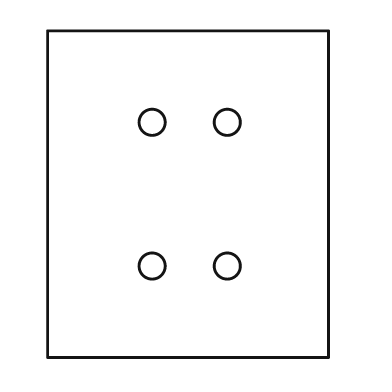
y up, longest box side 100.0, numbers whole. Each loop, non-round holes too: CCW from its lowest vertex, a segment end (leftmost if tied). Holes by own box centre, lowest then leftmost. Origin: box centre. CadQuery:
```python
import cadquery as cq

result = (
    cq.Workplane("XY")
    .moveTo(-43.0, -50.0)
    .lineTo(43.0, -50.0)
    .lineTo(43.0, 50.0)
    .lineTo(-43.0, 50.0)
    .close()
    .moveTo(-11.0, -22.0)
    .circle(4.0)
    .moveTo(12.0, -22.0)
    .circle(4.0)
    .moveTo(-11.0, 22.0)
    .circle(4.0)
    .moveTo(12.0, 22.0)
    .circle(4.0)
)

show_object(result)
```